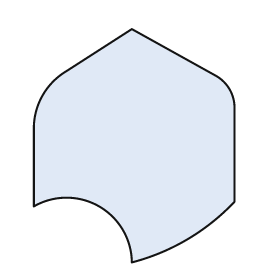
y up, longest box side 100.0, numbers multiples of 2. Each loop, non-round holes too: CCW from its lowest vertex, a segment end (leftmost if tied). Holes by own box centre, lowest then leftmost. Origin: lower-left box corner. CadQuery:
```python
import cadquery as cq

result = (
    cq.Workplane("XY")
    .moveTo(42.0, 0.0)
    .threePointArc((66.0, 10.0), (86.0, 26.0))
    .lineTo(86.0, 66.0)
    .threePointArc((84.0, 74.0), (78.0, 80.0))
    .lineTo(42.0, 100.0)
    .lineTo(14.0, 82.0)
    .threePointArc((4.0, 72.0), (0.0, 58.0))
    .lineTo(0.0, 24.0)
    .threePointArc((28.0, 24.0), (42.0, 0.0))
    .close()
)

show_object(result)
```